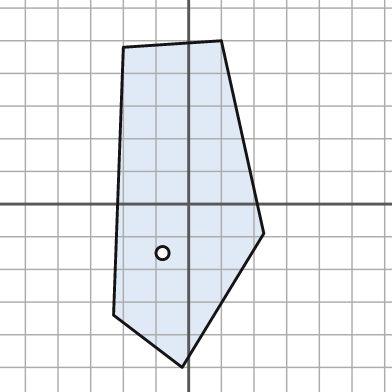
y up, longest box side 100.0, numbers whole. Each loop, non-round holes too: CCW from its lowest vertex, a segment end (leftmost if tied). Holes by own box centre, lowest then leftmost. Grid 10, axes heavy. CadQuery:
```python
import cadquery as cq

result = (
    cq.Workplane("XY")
    .moveTo(-2.0, -50.0)
    .lineTo(23.0, -9.0)
    .lineTo(10.0, 50.0)
    .lineTo(-20.0, 48.0)
    .lineTo(-23.0, -34.0)
    .close()
    .moveTo(-8.0, -15.0)
    .circle(2.0)
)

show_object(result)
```